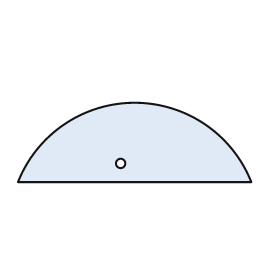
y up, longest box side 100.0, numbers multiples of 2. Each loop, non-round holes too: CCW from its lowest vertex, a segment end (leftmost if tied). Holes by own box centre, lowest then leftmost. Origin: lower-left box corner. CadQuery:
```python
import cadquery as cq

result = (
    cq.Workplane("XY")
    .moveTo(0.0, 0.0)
    .lineTo(100.0, 0.0)
    .threePointArc((50.0, 34.0), (0.0, 0.0))
    .close()
    .moveTo(44.0, 8.0)
    .circle(2.0)
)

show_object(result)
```